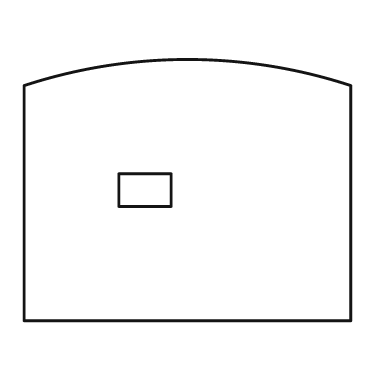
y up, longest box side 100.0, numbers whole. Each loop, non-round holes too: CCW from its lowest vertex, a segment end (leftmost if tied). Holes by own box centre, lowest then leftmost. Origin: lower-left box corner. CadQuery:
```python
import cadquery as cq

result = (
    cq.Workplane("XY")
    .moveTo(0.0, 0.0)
    .lineTo(100.0, 0.0)
    .lineTo(100.0, 72.0)
    .threePointArc((50.0, 80.0), (0.0, 72.0))
    .close()
    .moveTo(29.0, 35.0)
    .lineTo(45.0, 35.0)
    .lineTo(45.0, 45.0)
    .lineTo(29.0, 45.0)
    .close()
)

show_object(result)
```